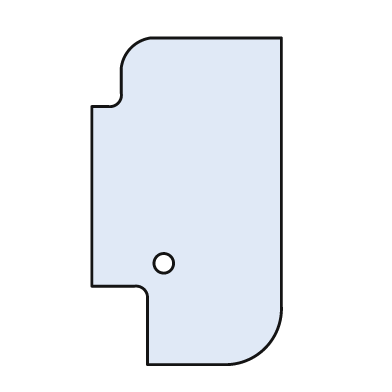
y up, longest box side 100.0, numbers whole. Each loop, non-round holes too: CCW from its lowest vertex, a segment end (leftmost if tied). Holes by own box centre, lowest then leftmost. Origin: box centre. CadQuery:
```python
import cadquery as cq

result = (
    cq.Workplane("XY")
    .moveTo(-12.0, -50.0)
    .lineTo(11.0, -50.0)
    .threePointArc((24.0, -45.0), (29.0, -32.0))
    .lineTo(29.0, 50.0)
    .lineTo(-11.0, 50.0)
    .threePointArc((-17.0, 47.0), (-20.0, 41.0))
    .lineTo(-20.0, 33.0)
    .threePointArc((-21.0, 30.0), (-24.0, 29.0))
    .lineTo(-29.0, 29.0)
    .lineTo(-29.0, -26.0)
    .lineTo(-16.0, -26.0)
    .threePointArc((-13.0, -27.0), (-12.0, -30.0))
    .close()
    .moveTo(-7.0, -19.0)
    .circle(3.0)
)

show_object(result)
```